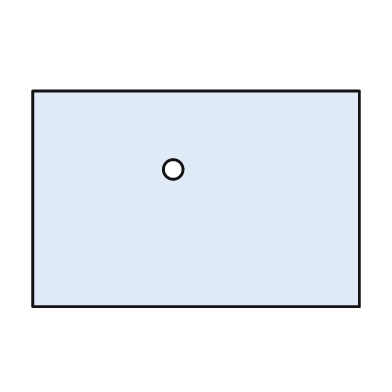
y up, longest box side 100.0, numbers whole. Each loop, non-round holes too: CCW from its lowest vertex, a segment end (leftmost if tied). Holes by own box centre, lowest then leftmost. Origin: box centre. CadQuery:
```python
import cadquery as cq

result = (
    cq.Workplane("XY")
    .moveTo(-50.0, -33.0)
    .lineTo(50.0, -33.0)
    .lineTo(50.0, 33.0)
    .lineTo(-50.0, 33.0)
    .close()
    .moveTo(-7.0, 9.0)
    .circle(3.0)
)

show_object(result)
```